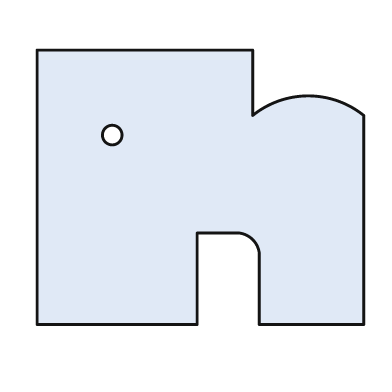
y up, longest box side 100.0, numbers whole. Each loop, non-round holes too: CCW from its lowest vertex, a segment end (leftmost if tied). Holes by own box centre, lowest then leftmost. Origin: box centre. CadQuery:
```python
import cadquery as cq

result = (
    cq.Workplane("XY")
    .moveTo(-50.0, -42.0)
    .lineTo(-1.0, -42.0)
    .lineTo(-1.0, -14.0)
    .lineTo(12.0, -14.0)
    .threePointArc((16.0, -16.0), (18.0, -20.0))
    .lineTo(18.0, -42.0)
    .lineTo(50.0, -42.0)
    .lineTo(50.0, 22.0)
    .threePointArc((33.0, 28.0), (16.0, 22.0))
    .lineTo(16.0, 42.0)
    .lineTo(-50.0, 42.0)
    .close()
    .moveTo(-27.0, 16.0)
    .circle(3.0)
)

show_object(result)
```